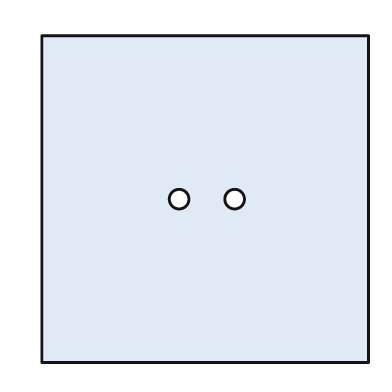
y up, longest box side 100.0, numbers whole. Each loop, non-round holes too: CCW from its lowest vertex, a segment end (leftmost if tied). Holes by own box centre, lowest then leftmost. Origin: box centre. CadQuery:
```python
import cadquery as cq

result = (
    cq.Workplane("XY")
    .moveTo(-50.0, -50.0)
    .lineTo(50.0, -50.0)
    .lineTo(50.0, 50.0)
    .lineTo(-50.0, 50.0)
    .close()
    .moveTo(-8.0, 0.0)
    .circle(3.0)
    .moveTo(9.0, 0.0)
    .circle(3.0)
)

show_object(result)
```